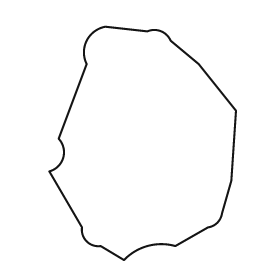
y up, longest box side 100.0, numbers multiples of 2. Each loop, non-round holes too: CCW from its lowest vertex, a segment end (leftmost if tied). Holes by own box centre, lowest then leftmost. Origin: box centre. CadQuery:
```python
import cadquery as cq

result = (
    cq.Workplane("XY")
    .moveTo(-8.0, -50.0)
    .threePointArc((2.0, -44.0), (14.0, -44.0))
    .lineTo(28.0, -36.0)
    .threePointArc((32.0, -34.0), (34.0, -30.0))
    .lineTo(38.0, -16.0)
    .lineTo(40.0, 14.0)
    .lineTo(24.0, 34.0)
    .lineTo(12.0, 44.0)
    .threePointArc((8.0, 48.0), (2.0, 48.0))
    .lineTo(-16.0, 50.0)
    .threePointArc((-24.0, 44.0), (-24.0, 34.0))
    .lineTo(-36.0, 2.0)
    .threePointArc((-34.0, -6.0), (-40.0, -12.0))
    .lineTo(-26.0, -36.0)
    .threePointArc((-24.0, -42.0), (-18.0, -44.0))
    .close()
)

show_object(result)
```